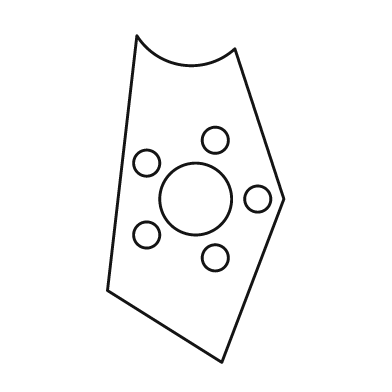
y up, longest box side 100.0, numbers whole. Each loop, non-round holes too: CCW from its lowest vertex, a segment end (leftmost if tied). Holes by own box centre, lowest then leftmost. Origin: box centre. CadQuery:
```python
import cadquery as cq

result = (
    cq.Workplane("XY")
    .moveTo(8.0, -50.0)
    .lineTo(27.0, 0.0)
    .lineTo(12.0, 46.0)
    .threePointArc((-4.0, 41.0), (-18.0, 50.0))
    .lineTo(-27.0, -28.0)
    .close()
    .moveTo(6.0, -18.0)
    .circle(4.0)
    .moveTo(-15.0, -11.0)
    .circle(4.0)
    .moveTo(0.0, 0.0)
    .circle(11.0)
    .moveTo(19.0, 0.0)
    .circle(4.0)
    .moveTo(-15.0, 11.0)
    .circle(4.0)
    .moveTo(6.0, 18.0)
    .circle(4.0)
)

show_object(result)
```